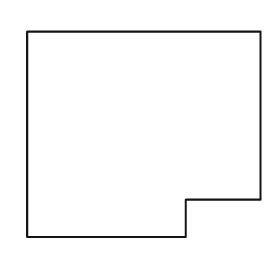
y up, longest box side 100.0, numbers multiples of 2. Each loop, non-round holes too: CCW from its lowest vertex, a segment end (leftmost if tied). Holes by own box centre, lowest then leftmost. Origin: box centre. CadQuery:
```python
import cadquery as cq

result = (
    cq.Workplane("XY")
    .moveTo(-50.0, -44.0)
    .lineTo(18.0, -44.0)
    .lineTo(18.0, -28.0)
    .lineTo(50.0, -28.0)
    .lineTo(50.0, 44.0)
    .lineTo(-50.0, 44.0)
    .close()
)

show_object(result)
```